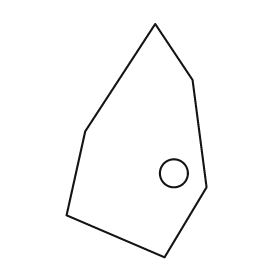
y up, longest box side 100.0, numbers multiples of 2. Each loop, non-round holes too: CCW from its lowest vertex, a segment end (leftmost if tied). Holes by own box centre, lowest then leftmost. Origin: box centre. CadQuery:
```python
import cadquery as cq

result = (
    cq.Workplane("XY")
    .moveTo(12.0, -50.0)
    .lineTo(30.0, -20.0)
    .lineTo(24.0, 26.0)
    .lineTo(8.0, 50.0)
    .lineTo(-22.0, 4.0)
    .lineTo(-30.0, -32.0)
    .close()
    .moveTo(16.0, -14.0)
    .circle(6.0)
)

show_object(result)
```